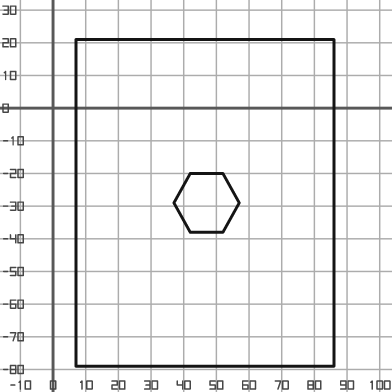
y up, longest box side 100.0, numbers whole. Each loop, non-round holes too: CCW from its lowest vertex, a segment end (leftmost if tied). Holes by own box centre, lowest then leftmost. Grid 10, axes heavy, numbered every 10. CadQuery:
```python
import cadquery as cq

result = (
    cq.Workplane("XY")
    .moveTo(7.0, -79.0)
    .lineTo(86.0, -79.0)
    .lineTo(86.0, 21.0)
    .lineTo(7.0, 21.0)
    .close()
    .moveTo(42.0, -38.0)
    .lineTo(52.0, -38.0)
    .lineTo(57.0, -29.0)
    .lineTo(52.0, -20.0)
    .lineTo(42.0, -20.0)
    .lineTo(37.0, -29.0)
    .close()
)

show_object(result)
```